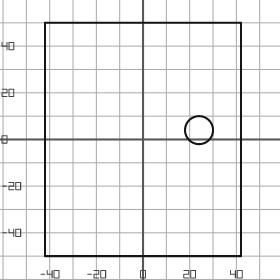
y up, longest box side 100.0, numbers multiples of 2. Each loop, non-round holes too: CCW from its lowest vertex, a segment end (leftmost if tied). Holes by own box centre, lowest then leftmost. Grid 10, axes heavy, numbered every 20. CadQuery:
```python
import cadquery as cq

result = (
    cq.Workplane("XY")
    .moveTo(-42.0, -50.0)
    .lineTo(42.0, -50.0)
    .lineTo(42.0, 50.0)
    .lineTo(-42.0, 50.0)
    .close()
    .moveTo(24.0, 4.0)
    .circle(6.0)
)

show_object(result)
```